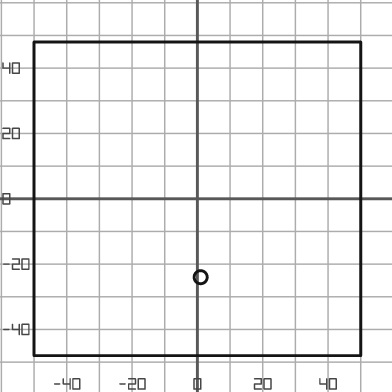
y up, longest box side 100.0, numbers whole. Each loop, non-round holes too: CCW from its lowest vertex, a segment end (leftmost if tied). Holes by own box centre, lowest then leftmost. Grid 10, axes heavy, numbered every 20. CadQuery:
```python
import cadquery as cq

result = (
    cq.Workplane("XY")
    .moveTo(-50.0, -48.0)
    .lineTo(50.0, -48.0)
    .lineTo(50.0, 48.0)
    .lineTo(-50.0, 48.0)
    .close()
    .moveTo(1.0, -24.0)
    .circle(2.0)
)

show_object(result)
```